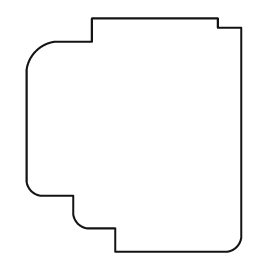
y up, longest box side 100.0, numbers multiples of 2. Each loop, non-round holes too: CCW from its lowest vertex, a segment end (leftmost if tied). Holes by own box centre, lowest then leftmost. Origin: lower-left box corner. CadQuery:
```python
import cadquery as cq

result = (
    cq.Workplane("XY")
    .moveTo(38.0, 0.0)
    .lineTo(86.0, 0.0)
    .threePointArc((90.0, 2.0), (92.0, 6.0))
    .lineTo(92.0, 96.0)
    .lineTo(82.0, 96.0)
    .lineTo(82.0, 100.0)
    .lineTo(28.0, 100.0)
    .lineTo(28.0, 90.0)
    .lineTo(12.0, 90.0)
    .threePointArc((4.0, 86.0), (0.0, 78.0))
    .lineTo(0.0, 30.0)
    .threePointArc((2.0, 26.0), (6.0, 24.0))
    .lineTo(20.0, 24.0)
    .lineTo(20.0, 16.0)
    .threePointArc((22.0, 12.0), (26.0, 10.0))
    .lineTo(38.0, 10.0)
    .close()
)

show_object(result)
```